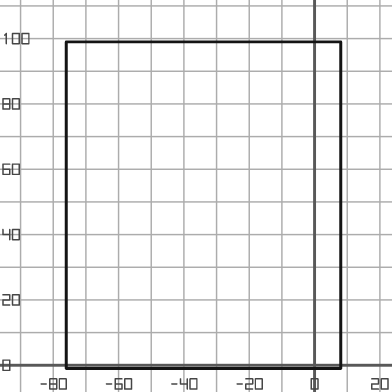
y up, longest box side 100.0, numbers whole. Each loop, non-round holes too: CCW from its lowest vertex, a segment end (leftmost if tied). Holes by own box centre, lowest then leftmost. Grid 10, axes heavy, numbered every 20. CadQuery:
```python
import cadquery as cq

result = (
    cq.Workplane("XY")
    .moveTo(-76.0, -1.0)
    .lineTo(8.0, -1.0)
    .lineTo(8.0, 99.0)
    .lineTo(-76.0, 99.0)
    .close()
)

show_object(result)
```